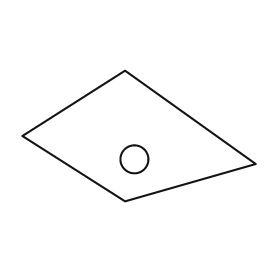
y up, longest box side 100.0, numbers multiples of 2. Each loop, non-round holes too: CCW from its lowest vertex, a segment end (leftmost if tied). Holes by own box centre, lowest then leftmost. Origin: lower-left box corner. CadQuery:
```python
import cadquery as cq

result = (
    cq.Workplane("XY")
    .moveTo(44.0, 0.0)
    .lineTo(100.0, 16.0)
    .lineTo(44.0, 56.0)
    .lineTo(0.0, 28.0)
    .close()
    .moveTo(48.0, 18.0)
    .circle(6.0)
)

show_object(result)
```